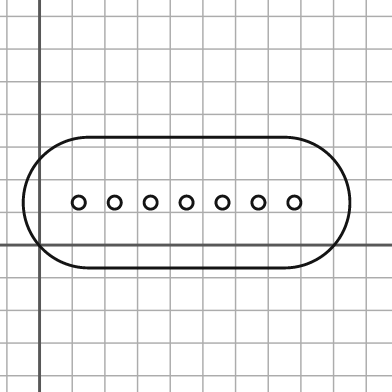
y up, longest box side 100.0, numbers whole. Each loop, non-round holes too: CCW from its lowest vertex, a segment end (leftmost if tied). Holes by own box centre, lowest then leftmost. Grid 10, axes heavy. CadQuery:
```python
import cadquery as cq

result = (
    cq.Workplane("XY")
    .moveTo(15.0, -7.0)
    .lineTo(75.0, -7.0)
    .threePointArc((95.0, 13.0), (75.0, 33.0))
    .lineTo(15.0, 33.0)
    .threePointArc((-5.0, 13.0), (15.0, -7.0))
    .close()
    .moveTo(12.0, 13.0)
    .circle(2.0)
    .moveTo(23.0, 13.0)
    .circle(2.0)
    .moveTo(34.0, 13.0)
    .circle(2.0)
    .moveTo(45.0, 13.0)
    .circle(2.0)
    .moveTo(56.0, 13.0)
    .circle(2.0)
    .moveTo(67.0, 13.0)
    .circle(2.0)
    .moveTo(78.0, 13.0)
    .circle(2.0)
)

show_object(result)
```